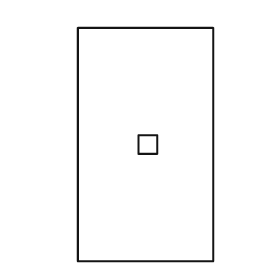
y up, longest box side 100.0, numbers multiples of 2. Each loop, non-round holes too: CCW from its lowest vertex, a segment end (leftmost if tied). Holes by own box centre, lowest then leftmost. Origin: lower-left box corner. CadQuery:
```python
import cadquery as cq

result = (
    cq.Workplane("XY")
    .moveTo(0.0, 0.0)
    .lineTo(58.0, 0.0)
    .lineTo(58.0, 100.0)
    .lineTo(0.0, 100.0)
    .close()
    .moveTo(26.0, 46.0)
    .lineTo(34.0, 46.0)
    .lineTo(34.0, 54.0)
    .lineTo(26.0, 54.0)
    .close()
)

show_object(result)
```